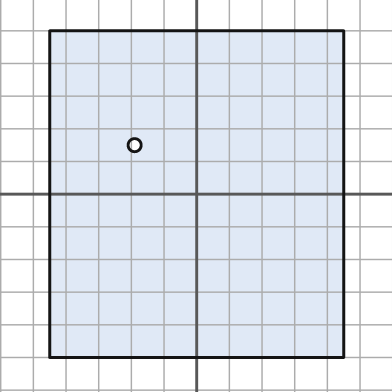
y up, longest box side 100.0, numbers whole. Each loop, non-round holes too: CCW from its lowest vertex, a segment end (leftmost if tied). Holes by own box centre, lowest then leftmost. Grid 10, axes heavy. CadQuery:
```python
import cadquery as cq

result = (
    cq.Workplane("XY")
    .moveTo(-45.0, -50.0)
    .lineTo(45.0, -50.0)
    .lineTo(45.0, 50.0)
    .lineTo(-45.0, 50.0)
    .close()
    .moveTo(-19.0, 15.0)
    .circle(2.0)
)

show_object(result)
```